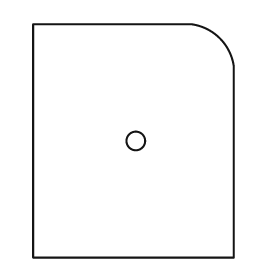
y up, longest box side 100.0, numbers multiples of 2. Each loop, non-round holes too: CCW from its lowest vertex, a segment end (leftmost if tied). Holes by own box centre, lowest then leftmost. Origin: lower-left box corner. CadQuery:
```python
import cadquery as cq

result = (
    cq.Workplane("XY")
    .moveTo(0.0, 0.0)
    .lineTo(86.0, 0.0)
    .lineTo(86.0, 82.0)
    .threePointArc((80.0, 94.0), (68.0, 100.0))
    .lineTo(0.0, 100.0)
    .close()
    .moveTo(44.0, 50.0)
    .circle(4.0)
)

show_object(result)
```